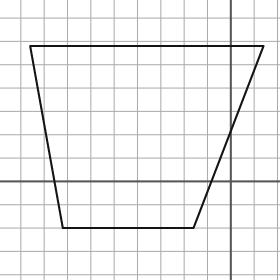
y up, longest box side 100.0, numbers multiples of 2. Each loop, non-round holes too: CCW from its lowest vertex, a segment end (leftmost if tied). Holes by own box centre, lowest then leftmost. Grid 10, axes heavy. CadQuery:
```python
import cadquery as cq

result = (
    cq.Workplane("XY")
    .moveTo(-72.0, -20.0)
    .lineTo(-16.0, -20.0)
    .lineTo(14.0, 58.0)
    .lineTo(-86.0, 58.0)
    .close()
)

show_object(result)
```